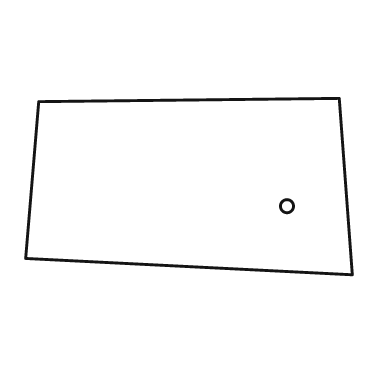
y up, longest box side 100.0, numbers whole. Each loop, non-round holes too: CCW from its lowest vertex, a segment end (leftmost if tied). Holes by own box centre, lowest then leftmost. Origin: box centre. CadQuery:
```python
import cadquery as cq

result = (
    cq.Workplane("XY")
    .moveTo(50.0, -27.0)
    .lineTo(46.0, 27.0)
    .lineTo(-46.0, 26.0)
    .lineTo(-50.0, -22.0)
    .close()
    .moveTo(30.0, -6.0)
    .circle(2.0)
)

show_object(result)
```